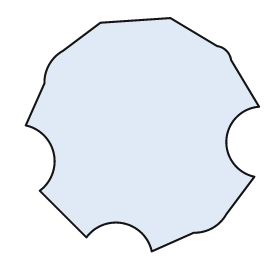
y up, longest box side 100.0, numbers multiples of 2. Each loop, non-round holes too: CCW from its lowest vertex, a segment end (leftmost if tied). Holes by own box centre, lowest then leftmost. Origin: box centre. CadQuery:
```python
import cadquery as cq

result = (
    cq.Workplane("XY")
    .moveTo(4.0, -50.0)
    .lineTo(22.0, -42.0)
    .threePointArc((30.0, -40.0), (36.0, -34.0))
    .lineTo(48.0, -18.0)
    .threePointArc((36.0, -2.0), (50.0, 12.0))
    .lineTo(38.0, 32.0)
    .threePointArc((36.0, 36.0), (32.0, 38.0))
    .lineTo(12.0, 50.0)
    .lineTo(-18.0, 48.0)
    .lineTo(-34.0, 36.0)
    .threePointArc((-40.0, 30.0), (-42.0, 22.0))
    .lineTo(-50.0, 4.0)
    .threePointArc((-38.0, -8.0), (-44.0, -24.0))
    .lineTo(-24.0, -44.0)
    .threePointArc((-8.0, -38.0), (4.0, -50.0))
    .close()
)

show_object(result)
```